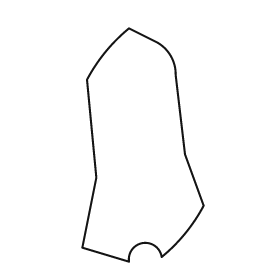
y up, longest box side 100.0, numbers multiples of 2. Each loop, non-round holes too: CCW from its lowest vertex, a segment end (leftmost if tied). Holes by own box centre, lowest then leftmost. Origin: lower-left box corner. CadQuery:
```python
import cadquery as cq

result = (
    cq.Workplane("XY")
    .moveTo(20.0, 0.0)
    .threePointArc((26.0, 8.0), (34.0, 2.0))
    .threePointArc((44.0, 12.0), (52.0, 24.0))
    .lineTo(44.0, 46.0)
    .lineTo(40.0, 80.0)
    .threePointArc((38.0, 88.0), (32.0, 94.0))
    .lineTo(20.0, 100.0)
    .threePointArc((10.0, 90.0), (2.0, 78.0))
    .lineTo(6.0, 36.0)
    .lineTo(0.0, 6.0)
    .close()
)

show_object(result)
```